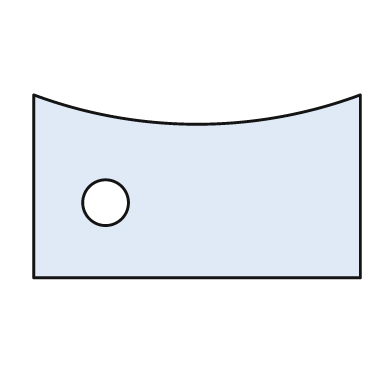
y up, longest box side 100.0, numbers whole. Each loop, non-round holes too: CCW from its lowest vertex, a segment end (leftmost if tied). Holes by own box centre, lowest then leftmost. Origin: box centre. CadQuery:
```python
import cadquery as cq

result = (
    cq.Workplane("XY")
    .moveTo(-50.0, -28.0)
    .lineTo(50.0, -28.0)
    .lineTo(50.0, 28.0)
    .threePointArc((0.0, 19.0), (-50.0, 28.0))
    .close()
    .moveTo(-28.0, -5.0)
    .circle(7.0)
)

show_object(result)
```